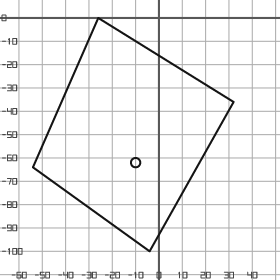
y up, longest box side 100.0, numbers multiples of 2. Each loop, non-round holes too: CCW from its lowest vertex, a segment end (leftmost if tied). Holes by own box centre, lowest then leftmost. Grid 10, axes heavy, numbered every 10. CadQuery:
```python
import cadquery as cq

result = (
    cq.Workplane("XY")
    .moveTo(-4.0, -100.0)
    .lineTo(32.0, -36.0)
    .lineTo(-26.0, 0.0)
    .lineTo(-54.0, -64.0)
    .close()
    .moveTo(-10.0, -62.0)
    .circle(2.0)
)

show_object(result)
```